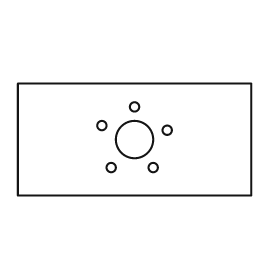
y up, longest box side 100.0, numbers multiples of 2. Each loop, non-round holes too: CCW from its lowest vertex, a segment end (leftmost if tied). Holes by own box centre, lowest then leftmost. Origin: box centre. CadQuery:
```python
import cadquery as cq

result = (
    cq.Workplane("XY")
    .moveTo(-50.0, -24.0)
    .lineTo(50.0, -24.0)
    .lineTo(50.0, 24.0)
    .lineTo(-50.0, 24.0)
    .close()
    .moveTo(-10.0, -12.0)
    .circle(2.0)
    .moveTo(8.0, -12.0)
    .circle(2.0)
    .moveTo(0.0, 0.0)
    .circle(8.0)
    .moveTo(14.0, 4.0)
    .circle(2.0)
    .moveTo(-14.0, 6.0)
    .circle(2.0)
    .moveTo(0.0, 14.0)
    .circle(2.0)
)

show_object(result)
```